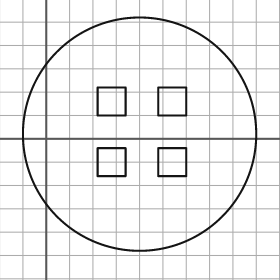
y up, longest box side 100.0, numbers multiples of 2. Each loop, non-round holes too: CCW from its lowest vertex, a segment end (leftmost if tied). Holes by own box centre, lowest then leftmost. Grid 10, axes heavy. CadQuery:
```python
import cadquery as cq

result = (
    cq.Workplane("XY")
    .moveTo(40.0, 2.0)
    .circle(50.0)
    .moveTo(22.0, -16.0)
    .lineTo(34.0, -16.0)
    .lineTo(34.0, -4.0)
    .lineTo(22.0, -4.0)
    .close()
    .moveTo(48.0, -16.0)
    .lineTo(60.0, -16.0)
    .lineTo(60.0, -4.0)
    .lineTo(48.0, -4.0)
    .close()
    .moveTo(22.0, 10.0)
    .lineTo(34.0, 10.0)
    .lineTo(34.0, 22.0)
    .lineTo(22.0, 22.0)
    .close()
    .moveTo(48.0, 10.0)
    .lineTo(60.0, 10.0)
    .lineTo(60.0, 22.0)
    .lineTo(48.0, 22.0)
    .close()
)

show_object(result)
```